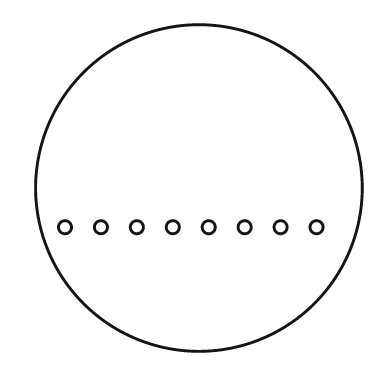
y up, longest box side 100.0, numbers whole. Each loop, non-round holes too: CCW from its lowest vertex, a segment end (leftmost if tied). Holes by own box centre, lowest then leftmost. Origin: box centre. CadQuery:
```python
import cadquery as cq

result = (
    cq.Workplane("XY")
    .moveTo(0.0, 0.0)
    .circle(50.0)
    .moveTo(-41.0, -12.0)
    .circle(2.0)
    .moveTo(-30.0, -12.0)
    .circle(2.0)
    .moveTo(-19.0, -12.0)
    .circle(2.0)
    .moveTo(-8.0, -12.0)
    .circle(2.0)
    .moveTo(3.0, -12.0)
    .circle(2.0)
    .moveTo(14.0, -12.0)
    .circle(2.0)
    .moveTo(25.0, -12.0)
    .circle(2.0)
    .moveTo(36.0, -12.0)
    .circle(2.0)
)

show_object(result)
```